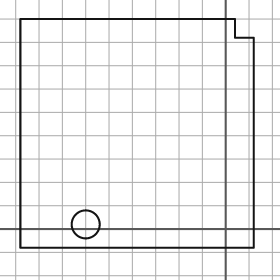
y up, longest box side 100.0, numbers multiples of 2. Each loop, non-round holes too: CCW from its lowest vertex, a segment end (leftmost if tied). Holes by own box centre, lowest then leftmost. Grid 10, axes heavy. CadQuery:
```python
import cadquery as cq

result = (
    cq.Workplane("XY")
    .moveTo(-88.0, -8.0)
    .lineTo(12.0, -8.0)
    .lineTo(12.0, 82.0)
    .lineTo(4.0, 82.0)
    .lineTo(4.0, 90.0)
    .lineTo(-88.0, 90.0)
    .close()
    .moveTo(-60.0, 2.0)
    .circle(6.0)
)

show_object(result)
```